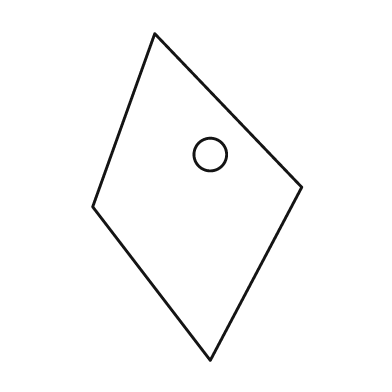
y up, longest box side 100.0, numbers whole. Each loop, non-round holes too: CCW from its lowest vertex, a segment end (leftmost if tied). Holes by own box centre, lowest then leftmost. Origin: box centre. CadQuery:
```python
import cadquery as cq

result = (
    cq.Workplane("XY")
    .moveTo(4.0, -50.0)
    .lineTo(32.0, 3.0)
    .lineTo(-13.0, 50.0)
    .lineTo(-32.0, -3.0)
    .close()
    .moveTo(4.0, 13.0)
    .circle(5.0)
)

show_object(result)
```